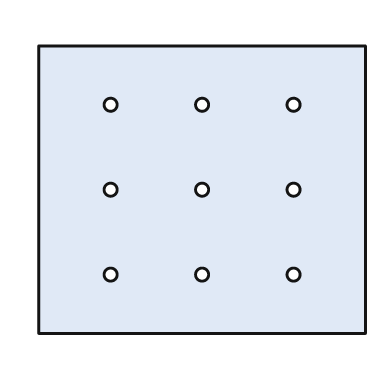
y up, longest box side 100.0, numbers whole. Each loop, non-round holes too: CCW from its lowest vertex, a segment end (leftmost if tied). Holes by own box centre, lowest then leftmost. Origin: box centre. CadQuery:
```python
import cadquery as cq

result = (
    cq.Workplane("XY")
    .moveTo(-50.0, -44.0)
    .lineTo(50.0, -44.0)
    .lineTo(50.0, 44.0)
    .lineTo(-50.0, 44.0)
    .close()
    .moveTo(-28.0, -26.0)
    .circle(2.0)
    .moveTo(0.0, -26.0)
    .circle(2.0)
    .moveTo(28.0, -26.0)
    .circle(2.0)
    .moveTo(-28.0, 0.0)
    .circle(2.0)
    .moveTo(0.0, 0.0)
    .circle(2.0)
    .moveTo(28.0, 0.0)
    .circle(2.0)
    .moveTo(-28.0, 26.0)
    .circle(2.0)
    .moveTo(0.0, 26.0)
    .circle(2.0)
    .moveTo(28.0, 26.0)
    .circle(2.0)
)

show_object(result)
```